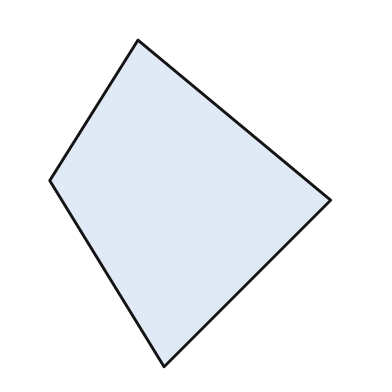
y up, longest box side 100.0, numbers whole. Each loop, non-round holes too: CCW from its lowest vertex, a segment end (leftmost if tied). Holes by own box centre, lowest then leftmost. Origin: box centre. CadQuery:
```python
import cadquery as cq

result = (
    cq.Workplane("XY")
    .moveTo(-8.0, -50.0)
    .lineTo(43.0, 1.0)
    .lineTo(-16.0, 50.0)
    .lineTo(-43.0, 7.0)
    .close()
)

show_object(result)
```